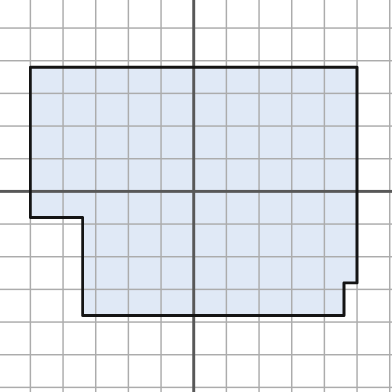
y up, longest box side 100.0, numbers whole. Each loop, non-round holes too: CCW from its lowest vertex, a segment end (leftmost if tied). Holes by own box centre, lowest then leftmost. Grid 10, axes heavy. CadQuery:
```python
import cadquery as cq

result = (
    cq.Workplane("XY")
    .moveTo(-34.0, -38.0)
    .lineTo(46.0, -38.0)
    .lineTo(46.0, -28.0)
    .lineTo(50.0, -28.0)
    .lineTo(50.0, 38.0)
    .lineTo(-50.0, 38.0)
    .lineTo(-50.0, -8.0)
    .lineTo(-34.0, -8.0)
    .close()
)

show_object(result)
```